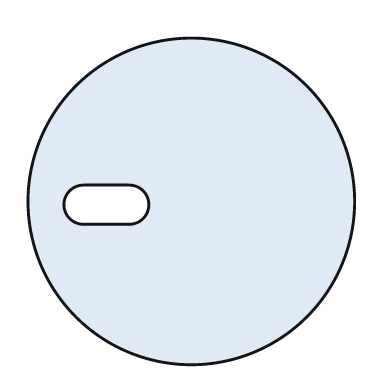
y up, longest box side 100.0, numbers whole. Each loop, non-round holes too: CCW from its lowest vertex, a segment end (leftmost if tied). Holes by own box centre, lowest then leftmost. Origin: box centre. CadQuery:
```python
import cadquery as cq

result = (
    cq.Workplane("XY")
    .moveTo(0.0, 0.0)
    .circle(50.0)
    .moveTo(-33.0, -7.0)
    .lineTo(-19.0, -7.0)
    .threePointArc((-13.0, -1.0), (-19.0, 5.0))
    .lineTo(-33.0, 5.0)
    .threePointArc((-39.0, -1.0), (-33.0, -7.0))
    .close()
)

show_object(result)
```